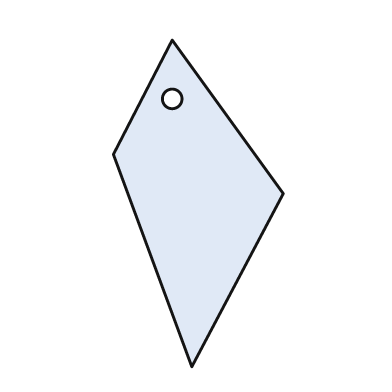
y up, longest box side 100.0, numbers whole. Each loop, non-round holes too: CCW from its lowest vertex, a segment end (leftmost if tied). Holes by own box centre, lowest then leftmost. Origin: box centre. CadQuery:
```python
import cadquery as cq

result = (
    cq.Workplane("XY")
    .moveTo(-2.0, -50.0)
    .lineTo(26.0, 3.0)
    .lineTo(-8.0, 50.0)
    .lineTo(-26.0, 15.0)
    .close()
    .moveTo(-8.0, 32.0)
    .circle(3.0)
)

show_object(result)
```